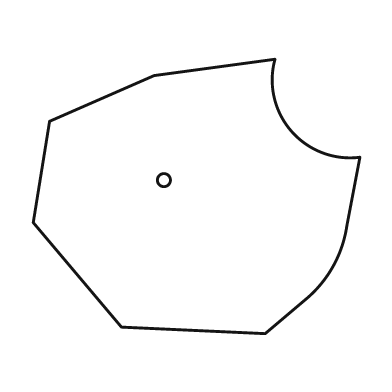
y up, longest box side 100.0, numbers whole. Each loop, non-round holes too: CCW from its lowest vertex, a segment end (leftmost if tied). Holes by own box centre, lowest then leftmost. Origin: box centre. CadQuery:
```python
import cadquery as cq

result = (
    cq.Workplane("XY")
    .moveTo(21.0, -42.0)
    .lineTo(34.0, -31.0)
    .threePointArc((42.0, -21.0), (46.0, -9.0))
    .lineTo(50.0, 12.0)
    .threePointArc((29.0, 20.0), (24.0, 42.0))
    .lineTo(-13.0, 37.0)
    .lineTo(-45.0, 23.0)
    .lineTo(-50.0, -8.0)
    .lineTo(-23.0, -40.0)
    .close()
    .moveTo(-10.0, 5.0)
    .circle(2.0)
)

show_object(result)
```